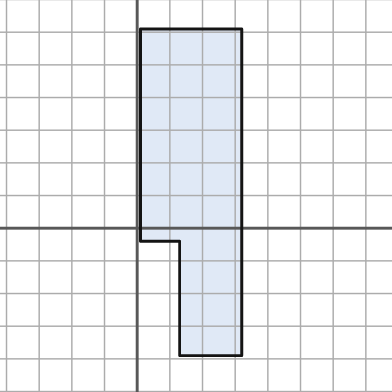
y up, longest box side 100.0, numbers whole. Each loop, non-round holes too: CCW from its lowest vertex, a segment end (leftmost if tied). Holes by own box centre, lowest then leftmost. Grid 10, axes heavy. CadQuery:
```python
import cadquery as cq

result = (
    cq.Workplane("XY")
    .moveTo(13.0, -39.0)
    .lineTo(32.0, -39.0)
    .lineTo(32.0, 61.0)
    .lineTo(1.0, 61.0)
    .lineTo(1.0, -4.0)
    .lineTo(13.0, -4.0)
    .close()
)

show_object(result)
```